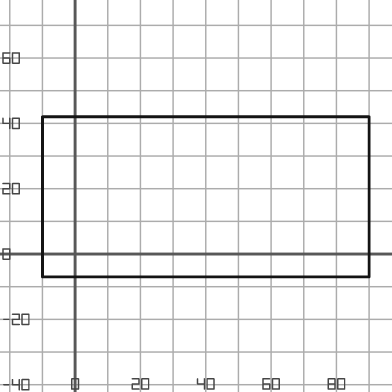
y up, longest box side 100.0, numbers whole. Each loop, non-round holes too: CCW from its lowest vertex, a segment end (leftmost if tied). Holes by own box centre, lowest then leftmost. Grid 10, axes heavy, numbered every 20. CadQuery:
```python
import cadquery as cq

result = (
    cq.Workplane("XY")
    .moveTo(-10.0, -7.0)
    .lineTo(90.0, -7.0)
    .lineTo(90.0, 42.0)
    .lineTo(-10.0, 42.0)
    .close()
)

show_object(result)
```